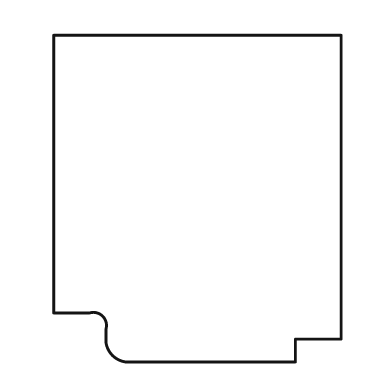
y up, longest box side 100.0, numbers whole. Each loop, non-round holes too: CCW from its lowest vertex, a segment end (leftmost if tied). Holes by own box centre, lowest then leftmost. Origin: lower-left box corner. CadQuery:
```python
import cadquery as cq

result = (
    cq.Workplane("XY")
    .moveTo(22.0, 0.0)
    .lineTo(74.0, 0.0)
    .lineTo(74.0, 7.0)
    .lineTo(88.0, 7.0)
    .lineTo(88.0, 100.0)
    .lineTo(0.0, 100.0)
    .lineTo(0.0, 15.0)
    .lineTo(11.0, 15.0)
    .threePointArc((15.0, 14.0), (16.0, 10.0))
    .lineTo(16.0, 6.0)
    .threePointArc((18.0, 2.0), (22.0, 0.0))
    .close()
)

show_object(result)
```